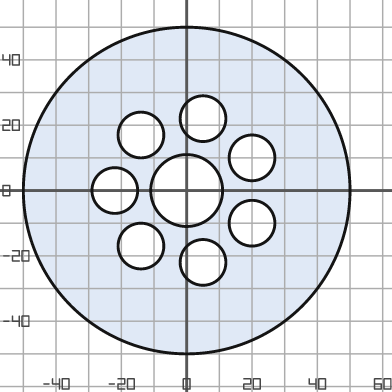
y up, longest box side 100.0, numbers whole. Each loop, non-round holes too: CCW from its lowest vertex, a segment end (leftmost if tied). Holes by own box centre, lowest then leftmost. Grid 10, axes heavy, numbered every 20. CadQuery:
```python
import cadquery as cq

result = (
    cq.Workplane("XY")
    .moveTo(0.0, 0.0)
    .circle(50.0)
    .moveTo(5.0, -22.0)
    .circle(7.0)
    .moveTo(-14.0, -17.0)
    .circle(7.0)
    .moveTo(20.0, -10.0)
    .circle(7.0)
    .moveTo(-22.0, 0.0)
    .circle(7.0)
    .moveTo(0.0, 0.0)
    .circle(11.0)
    .moveTo(20.0, 10.0)
    .circle(7.0)
    .moveTo(-14.0, 17.0)
    .circle(7.0)
    .moveTo(5.0, 22.0)
    .circle(7.0)
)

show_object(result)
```